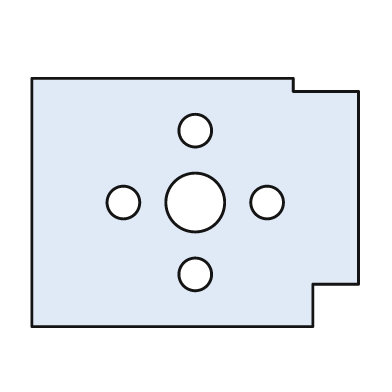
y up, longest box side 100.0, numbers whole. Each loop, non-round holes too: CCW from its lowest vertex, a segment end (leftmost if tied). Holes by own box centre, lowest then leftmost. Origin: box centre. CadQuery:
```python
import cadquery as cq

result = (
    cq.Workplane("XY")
    .moveTo(-50.0, -38.0)
    .lineTo(36.0, -38.0)
    .lineTo(36.0, -25.0)
    .lineTo(50.0, -25.0)
    .lineTo(50.0, 34.0)
    .lineTo(30.0, 34.0)
    .lineTo(30.0, 38.0)
    .lineTo(-50.0, 38.0)
    .close()
    .moveTo(0.0, -22.0)
    .circle(5.0)
    .moveTo(-22.0, 0.0)
    .circle(5.0)
    .moveTo(0.0, 0.0)
    .circle(9.0)
    .moveTo(22.0, 0.0)
    .circle(5.0)
    .moveTo(0.0, 22.0)
    .circle(5.0)
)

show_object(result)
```